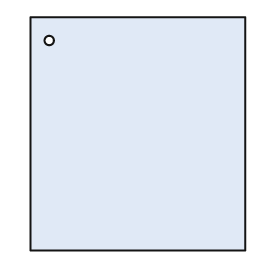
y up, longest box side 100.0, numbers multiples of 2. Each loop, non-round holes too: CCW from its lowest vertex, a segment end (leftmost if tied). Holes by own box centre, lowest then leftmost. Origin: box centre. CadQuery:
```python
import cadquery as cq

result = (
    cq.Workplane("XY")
    .moveTo(-46.0, -50.0)
    .lineTo(46.0, -50.0)
    .lineTo(46.0, 50.0)
    .lineTo(-46.0, 50.0)
    .close()
    .moveTo(-38.0, 40.0)
    .circle(2.0)
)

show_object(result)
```